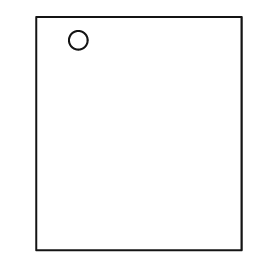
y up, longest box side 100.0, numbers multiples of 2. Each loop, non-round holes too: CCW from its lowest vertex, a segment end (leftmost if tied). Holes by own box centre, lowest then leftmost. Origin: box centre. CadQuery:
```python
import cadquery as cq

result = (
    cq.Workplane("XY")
    .moveTo(-44.0, -50.0)
    .lineTo(44.0, -50.0)
    .lineTo(44.0, 50.0)
    .lineTo(-44.0, 50.0)
    .close()
    .moveTo(-26.0, 40.0)
    .circle(4.0)
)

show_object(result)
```